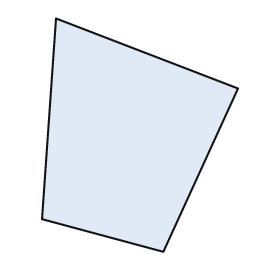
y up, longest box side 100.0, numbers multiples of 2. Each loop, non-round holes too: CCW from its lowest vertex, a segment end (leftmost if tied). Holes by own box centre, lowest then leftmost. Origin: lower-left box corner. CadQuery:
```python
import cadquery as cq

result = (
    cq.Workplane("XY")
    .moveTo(52.0, 0.0)
    .lineTo(84.0, 70.0)
    .lineTo(6.0, 100.0)
    .lineTo(0.0, 14.0)
    .close()
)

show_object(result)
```